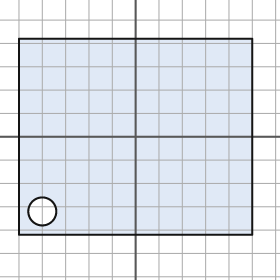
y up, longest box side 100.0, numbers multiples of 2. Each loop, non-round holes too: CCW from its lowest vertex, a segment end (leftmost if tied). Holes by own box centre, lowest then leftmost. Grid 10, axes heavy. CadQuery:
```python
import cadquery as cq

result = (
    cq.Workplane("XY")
    .moveTo(-50.0, -42.0)
    .lineTo(50.0, -42.0)
    .lineTo(50.0, 42.0)
    .lineTo(-50.0, 42.0)
    .close()
    .moveTo(-40.0, -32.0)
    .circle(6.0)
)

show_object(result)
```